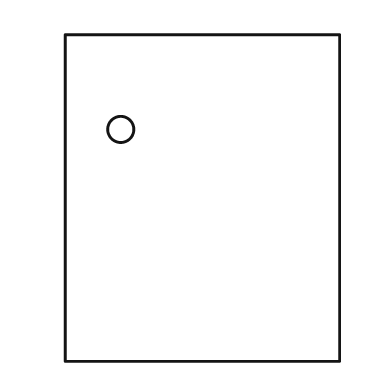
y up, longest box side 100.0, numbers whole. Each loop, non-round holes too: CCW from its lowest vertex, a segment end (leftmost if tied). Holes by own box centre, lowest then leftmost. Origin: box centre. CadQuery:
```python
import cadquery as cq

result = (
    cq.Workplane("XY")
    .moveTo(-42.0, -50.0)
    .lineTo(42.0, -50.0)
    .lineTo(42.0, 50.0)
    .lineTo(-42.0, 50.0)
    .close()
    .moveTo(-25.0, 21.0)
    .circle(4.0)
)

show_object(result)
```